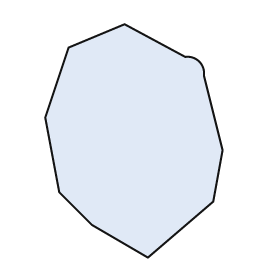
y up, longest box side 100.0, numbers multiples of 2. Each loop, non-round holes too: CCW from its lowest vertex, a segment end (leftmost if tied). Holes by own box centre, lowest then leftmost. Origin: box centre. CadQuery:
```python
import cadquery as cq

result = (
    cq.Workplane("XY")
    .moveTo(6.0, -50.0)
    .lineTo(34.0, -26.0)
    .lineTo(38.0, -4.0)
    .lineTo(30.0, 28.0)
    .threePointArc((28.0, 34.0), (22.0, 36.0))
    .lineTo(-4.0, 50.0)
    .lineTo(-28.0, 40.0)
    .lineTo(-38.0, 10.0)
    .lineTo(-32.0, -22.0)
    .lineTo(-18.0, -36.0)
    .close()
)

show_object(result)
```